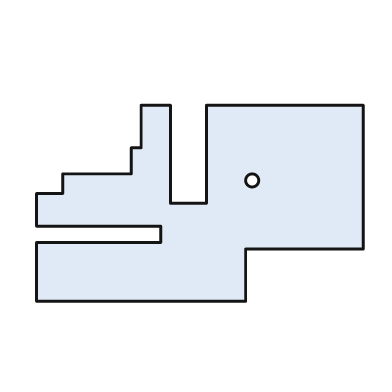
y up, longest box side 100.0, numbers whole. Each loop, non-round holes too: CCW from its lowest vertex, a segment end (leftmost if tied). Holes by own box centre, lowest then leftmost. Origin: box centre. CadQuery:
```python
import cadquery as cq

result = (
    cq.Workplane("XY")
    .moveTo(-50.0, -30.0)
    .lineTo(14.0, -30.0)
    .lineTo(14.0, -14.0)
    .lineTo(50.0, -14.0)
    .lineTo(50.0, 30.0)
    .lineTo(2.0, 30.0)
    .lineTo(2.0, 0.0)
    .lineTo(-9.0, 0.0)
    .lineTo(-9.0, 30.0)
    .lineTo(-18.0, 30.0)
    .lineTo(-18.0, 17.0)
    .lineTo(-21.0, 17.0)
    .lineTo(-21.0, 9.0)
    .lineTo(-42.0, 9.0)
    .lineTo(-42.0, 3.0)
    .lineTo(-50.0, 3.0)
    .lineTo(-50.0, -7.0)
    .lineTo(-12.0, -7.0)
    .lineTo(-12.0, -12.0)
    .lineTo(-50.0, -12.0)
    .close()
    .moveTo(16.0, 7.0)
    .circle(2.0)
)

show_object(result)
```